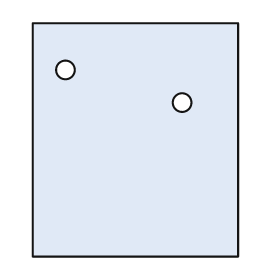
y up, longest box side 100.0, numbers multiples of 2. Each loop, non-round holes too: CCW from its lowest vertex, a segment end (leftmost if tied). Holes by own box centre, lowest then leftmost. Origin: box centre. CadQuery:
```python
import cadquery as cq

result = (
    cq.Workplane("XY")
    .moveTo(-44.0, -50.0)
    .lineTo(44.0, -50.0)
    .lineTo(44.0, 50.0)
    .lineTo(-44.0, 50.0)
    .close()
    .moveTo(20.0, 16.0)
    .circle(4.0)
    .moveTo(-30.0, 30.0)
    .circle(4.0)
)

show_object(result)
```